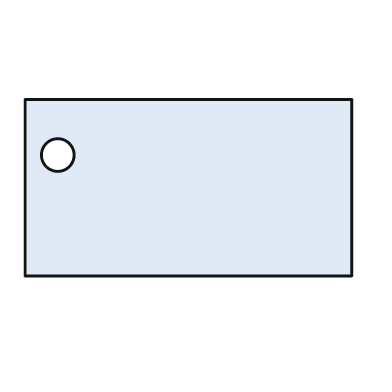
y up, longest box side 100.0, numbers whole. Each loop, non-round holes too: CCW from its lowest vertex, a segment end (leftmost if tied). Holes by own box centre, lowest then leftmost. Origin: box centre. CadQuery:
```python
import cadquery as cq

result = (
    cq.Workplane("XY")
    .moveTo(-50.0, -27.0)
    .lineTo(50.0, -27.0)
    .lineTo(50.0, 27.0)
    .lineTo(-50.0, 27.0)
    .close()
    .moveTo(-40.0, 10.0)
    .circle(5.0)
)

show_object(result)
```